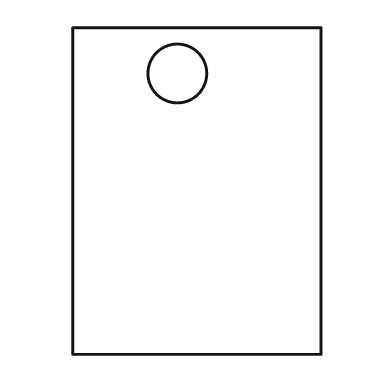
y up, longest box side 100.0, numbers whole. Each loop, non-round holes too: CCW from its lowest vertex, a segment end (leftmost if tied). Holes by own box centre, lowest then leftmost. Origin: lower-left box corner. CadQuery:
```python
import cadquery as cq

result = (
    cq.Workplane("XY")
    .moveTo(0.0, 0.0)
    .lineTo(76.0, 0.0)
    .lineTo(76.0, 100.0)
    .lineTo(0.0, 100.0)
    .close()
    .moveTo(32.0, 86.0)
    .circle(9.0)
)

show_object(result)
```